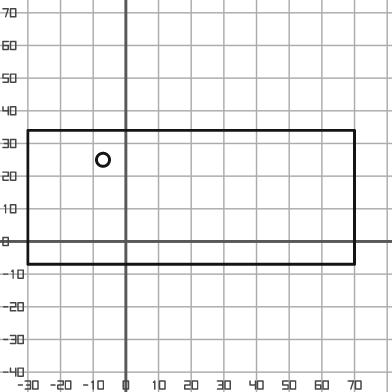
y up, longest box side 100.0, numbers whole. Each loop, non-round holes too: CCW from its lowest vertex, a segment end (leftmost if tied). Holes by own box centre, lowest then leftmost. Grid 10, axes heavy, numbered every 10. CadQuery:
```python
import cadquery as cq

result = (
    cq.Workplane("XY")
    .moveTo(-30.0, -7.0)
    .lineTo(70.0, -7.0)
    .lineTo(70.0, 34.0)
    .lineTo(-30.0, 34.0)
    .close()
    .moveTo(-7.0, 25.0)
    .circle(2.0)
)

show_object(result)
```